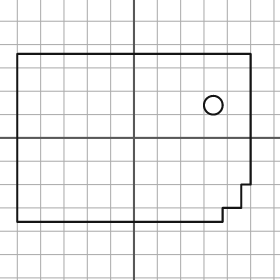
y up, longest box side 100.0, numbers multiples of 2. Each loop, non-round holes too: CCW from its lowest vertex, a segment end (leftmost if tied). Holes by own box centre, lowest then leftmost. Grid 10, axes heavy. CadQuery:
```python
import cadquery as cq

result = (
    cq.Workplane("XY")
    .moveTo(-50.0, -36.0)
    .lineTo(38.0, -36.0)
    .lineTo(38.0, -30.0)
    .lineTo(46.0, -30.0)
    .lineTo(46.0, -20.0)
    .lineTo(50.0, -20.0)
    .lineTo(50.0, 36.0)
    .lineTo(-50.0, 36.0)
    .close()
    .moveTo(34.0, 14.0)
    .circle(4.0)
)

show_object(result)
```